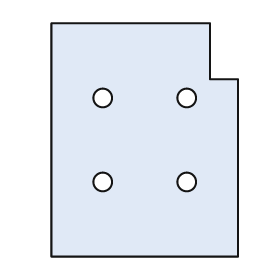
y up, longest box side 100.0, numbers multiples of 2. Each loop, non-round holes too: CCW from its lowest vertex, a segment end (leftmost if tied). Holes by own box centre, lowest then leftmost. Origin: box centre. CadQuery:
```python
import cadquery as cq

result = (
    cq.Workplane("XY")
    .moveTo(-40.0, -50.0)
    .lineTo(40.0, -50.0)
    .lineTo(40.0, 26.0)
    .lineTo(28.0, 26.0)
    .lineTo(28.0, 50.0)
    .lineTo(-40.0, 50.0)
    .close()
    .moveTo(-18.0, -18.0)
    .circle(4.0)
    .moveTo(18.0, -18.0)
    .circle(4.0)
    .moveTo(-18.0, 18.0)
    .circle(4.0)
    .moveTo(18.0, 18.0)
    .circle(4.0)
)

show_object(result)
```